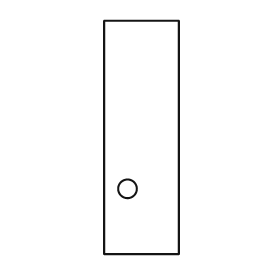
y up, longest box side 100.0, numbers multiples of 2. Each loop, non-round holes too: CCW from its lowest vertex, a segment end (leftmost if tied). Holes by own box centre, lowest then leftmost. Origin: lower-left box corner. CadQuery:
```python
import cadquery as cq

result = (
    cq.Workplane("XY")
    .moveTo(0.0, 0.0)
    .lineTo(32.0, 0.0)
    .lineTo(32.0, 100.0)
    .lineTo(0.0, 100.0)
    .close()
    .moveTo(10.0, 28.0)
    .circle(4.0)
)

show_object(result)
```